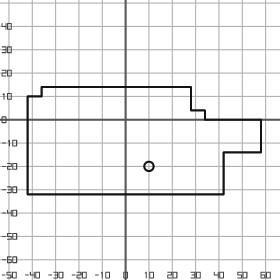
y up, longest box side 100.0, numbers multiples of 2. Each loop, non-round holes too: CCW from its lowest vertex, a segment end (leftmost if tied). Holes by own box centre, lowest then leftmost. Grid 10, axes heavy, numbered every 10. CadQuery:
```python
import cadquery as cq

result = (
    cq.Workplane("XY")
    .moveTo(-42.0, -32.0)
    .lineTo(42.0, -32.0)
    .lineTo(42.0, -14.0)
    .lineTo(58.0, -14.0)
    .lineTo(58.0, 0.0)
    .lineTo(34.0, 0.0)
    .lineTo(34.0, 4.0)
    .lineTo(28.0, 4.0)
    .lineTo(28.0, 14.0)
    .lineTo(-36.0, 14.0)
    .lineTo(-36.0, 10.0)
    .lineTo(-42.0, 10.0)
    .close()
    .moveTo(10.0, -20.0)
    .circle(2.0)
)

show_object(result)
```